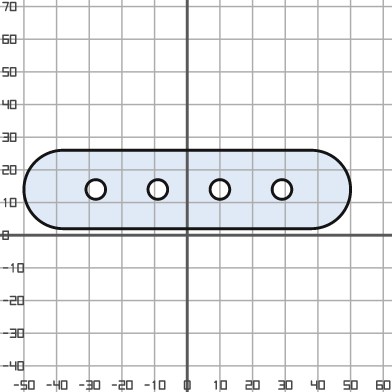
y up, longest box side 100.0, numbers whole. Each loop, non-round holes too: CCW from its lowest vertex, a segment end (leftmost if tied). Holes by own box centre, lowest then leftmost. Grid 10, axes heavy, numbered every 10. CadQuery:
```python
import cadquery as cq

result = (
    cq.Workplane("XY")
    .moveTo(-38.0, 2.0)
    .lineTo(38.0, 2.0)
    .threePointArc((50.0, 14.0), (38.0, 26.0))
    .lineTo(-38.0, 26.0)
    .threePointArc((-50.0, 14.0), (-38.0, 2.0))
    .close()
    .moveTo(-28.0, 14.0)
    .circle(3.0)
    .moveTo(-9.0, 14.0)
    .circle(3.0)
    .moveTo(10.0, 14.0)
    .circle(3.0)
    .moveTo(29.0, 14.0)
    .circle(3.0)
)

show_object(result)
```